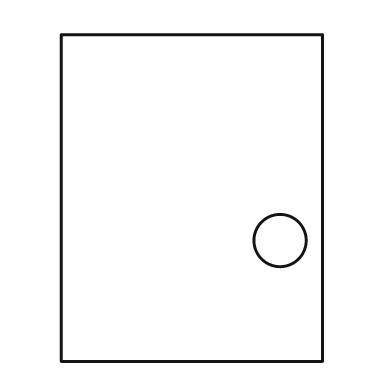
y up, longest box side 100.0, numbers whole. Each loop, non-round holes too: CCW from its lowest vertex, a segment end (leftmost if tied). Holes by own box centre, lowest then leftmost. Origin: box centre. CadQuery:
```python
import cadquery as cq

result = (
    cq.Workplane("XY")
    .moveTo(-40.0, -50.0)
    .lineTo(40.0, -50.0)
    .lineTo(40.0, 50.0)
    .lineTo(-40.0, 50.0)
    .close()
    .moveTo(27.0, -13.0)
    .circle(8.0)
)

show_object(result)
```